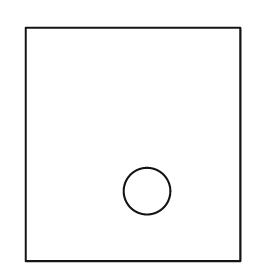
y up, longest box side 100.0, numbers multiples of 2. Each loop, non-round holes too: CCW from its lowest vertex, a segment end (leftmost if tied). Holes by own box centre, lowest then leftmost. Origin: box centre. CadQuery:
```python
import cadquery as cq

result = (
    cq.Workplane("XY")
    .moveTo(-46.0, -50.0)
    .lineTo(46.0, -50.0)
    .lineTo(46.0, 50.0)
    .lineTo(-46.0, 50.0)
    .close()
    .moveTo(6.0, -20.0)
    .circle(10.0)
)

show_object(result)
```